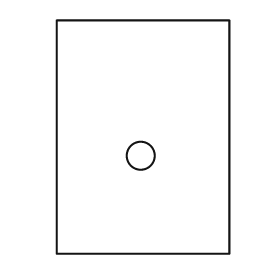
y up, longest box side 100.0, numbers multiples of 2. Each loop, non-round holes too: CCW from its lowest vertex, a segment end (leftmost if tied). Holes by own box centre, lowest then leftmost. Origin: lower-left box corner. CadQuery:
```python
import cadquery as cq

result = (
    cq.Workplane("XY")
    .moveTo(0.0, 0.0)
    .lineTo(74.0, 0.0)
    .lineTo(74.0, 100.0)
    .lineTo(0.0, 100.0)
    .close()
    .moveTo(36.0, 42.0)
    .circle(6.0)
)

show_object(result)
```